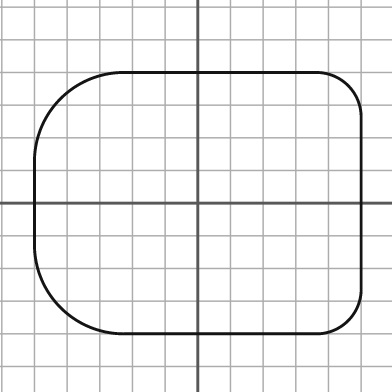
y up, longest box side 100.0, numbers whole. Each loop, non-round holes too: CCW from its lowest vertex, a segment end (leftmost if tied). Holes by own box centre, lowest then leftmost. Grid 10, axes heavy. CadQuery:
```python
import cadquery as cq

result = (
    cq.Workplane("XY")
    .moveTo(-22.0, -40.0)
    .lineTo(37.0, -40.0)
    .threePointArc((46.0, -36.0), (50.0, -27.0))
    .lineTo(50.0, 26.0)
    .threePointArc((46.0, 36.0), (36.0, 40.0))
    .lineTo(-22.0, 40.0)
    .threePointArc((-42.0, 32.0), (-50.0, 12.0))
    .lineTo(-50.0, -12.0)
    .threePointArc((-42.0, -32.0), (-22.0, -40.0))
    .close()
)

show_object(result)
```